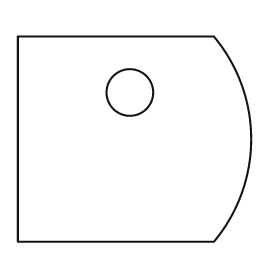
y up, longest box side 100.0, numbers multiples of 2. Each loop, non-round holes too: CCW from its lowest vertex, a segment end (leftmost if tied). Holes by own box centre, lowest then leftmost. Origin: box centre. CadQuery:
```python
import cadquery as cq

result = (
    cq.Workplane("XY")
    .moveTo(-50.0, -44.0)
    .lineTo(34.0, -44.0)
    .threePointArc((50.0, 0.0), (34.0, 44.0))
    .lineTo(-50.0, 44.0)
    .close()
    .moveTo(-2.0, 20.0)
    .circle(10.0)
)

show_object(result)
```